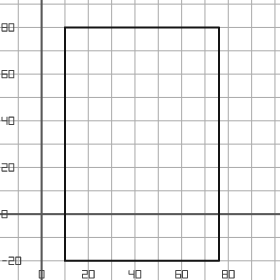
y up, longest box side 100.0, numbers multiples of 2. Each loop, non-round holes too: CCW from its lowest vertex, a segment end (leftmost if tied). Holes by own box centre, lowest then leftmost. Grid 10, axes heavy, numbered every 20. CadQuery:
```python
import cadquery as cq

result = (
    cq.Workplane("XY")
    .moveTo(10.0, -20.0)
    .lineTo(76.0, -20.0)
    .lineTo(76.0, 80.0)
    .lineTo(10.0, 80.0)
    .close()
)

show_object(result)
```